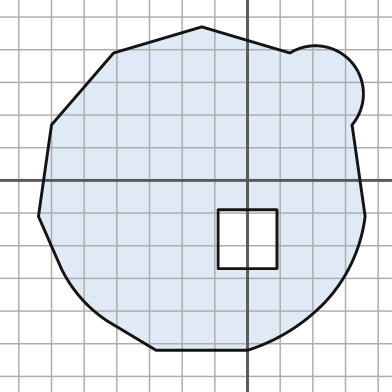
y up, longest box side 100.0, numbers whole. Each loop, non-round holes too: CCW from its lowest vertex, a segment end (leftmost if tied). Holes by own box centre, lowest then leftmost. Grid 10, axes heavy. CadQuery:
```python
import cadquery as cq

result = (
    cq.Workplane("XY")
    .moveTo(-28.0, -52.0)
    .lineTo(0.0, -52.0)
    .threePointArc((13.0, -46.0), (24.0, -37.0))
    .threePointArc((32.0, -25.0), (36.0, -11.0))
    .lineTo(32.0, 17.0)
    .threePointArc((32.0, 36.0), (13.0, 39.0))
    .lineTo(-14.0, 47.0)
    .lineTo(-41.0, 39.0)
    .lineTo(-60.0, 17.0)
    .lineTo(-64.0, -11.0)
    .lineTo(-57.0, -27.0)
    .threePointArc((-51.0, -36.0), (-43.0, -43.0))
    .close()
    .moveTo(-9.0, -27.0)
    .lineTo(9.0, -27.0)
    .lineTo(9.0, -9.0)
    .lineTo(-9.0, -9.0)
    .close()
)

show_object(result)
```